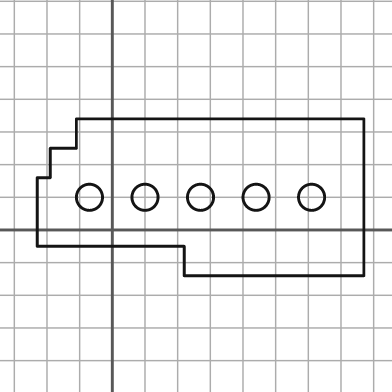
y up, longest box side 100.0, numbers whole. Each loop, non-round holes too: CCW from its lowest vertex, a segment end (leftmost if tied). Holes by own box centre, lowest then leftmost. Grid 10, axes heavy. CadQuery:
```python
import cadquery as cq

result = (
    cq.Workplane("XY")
    .moveTo(22.0, -14.0)
    .lineTo(77.0, -14.0)
    .lineTo(77.0, 34.0)
    .lineTo(-11.0, 34.0)
    .lineTo(-11.0, 25.0)
    .lineTo(-19.0, 25.0)
    .lineTo(-19.0, 16.0)
    .lineTo(-23.0, 16.0)
    .lineTo(-23.0, -5.0)
    .lineTo(22.0, -5.0)
    .close()
    .moveTo(-7.0, 10.0)
    .circle(4.0)
    .moveTo(10.0, 10.0)
    .circle(4.0)
    .moveTo(27.0, 10.0)
    .circle(4.0)
    .moveTo(44.0, 10.0)
    .circle(4.0)
    .moveTo(61.0, 10.0)
    .circle(4.0)
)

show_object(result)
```